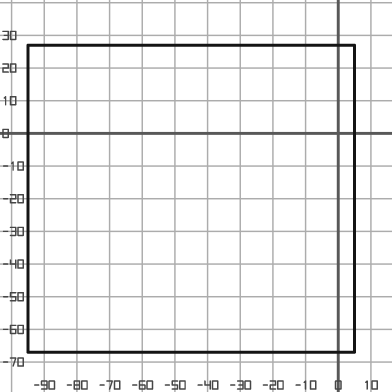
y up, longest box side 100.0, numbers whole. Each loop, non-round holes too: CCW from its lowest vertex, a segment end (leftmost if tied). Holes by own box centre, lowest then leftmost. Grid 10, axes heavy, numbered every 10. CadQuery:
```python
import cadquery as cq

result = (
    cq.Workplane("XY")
    .moveTo(-95.0, -67.0)
    .lineTo(5.0, -67.0)
    .lineTo(5.0, 27.0)
    .lineTo(-95.0, 27.0)
    .close()
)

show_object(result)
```